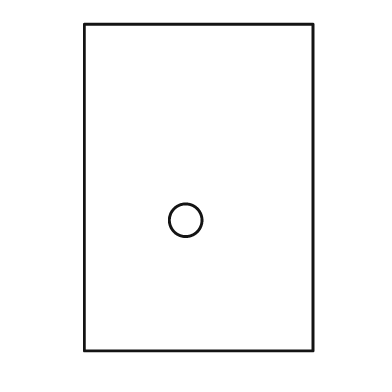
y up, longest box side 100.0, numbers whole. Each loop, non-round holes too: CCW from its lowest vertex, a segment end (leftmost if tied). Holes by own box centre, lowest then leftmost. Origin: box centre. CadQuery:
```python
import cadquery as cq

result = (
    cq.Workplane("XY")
    .moveTo(-35.0, -50.0)
    .lineTo(35.0, -50.0)
    .lineTo(35.0, 50.0)
    .lineTo(-35.0, 50.0)
    .close()
    .moveTo(-4.0, -10.0)
    .circle(5.0)
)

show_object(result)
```